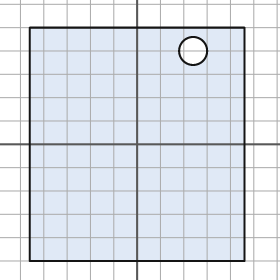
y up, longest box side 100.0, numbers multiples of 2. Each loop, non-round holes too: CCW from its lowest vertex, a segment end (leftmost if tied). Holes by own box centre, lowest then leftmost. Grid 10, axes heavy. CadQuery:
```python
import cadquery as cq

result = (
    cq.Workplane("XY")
    .moveTo(-46.0, -50.0)
    .lineTo(46.0, -50.0)
    .lineTo(46.0, 50.0)
    .lineTo(-46.0, 50.0)
    .close()
    .moveTo(24.0, 40.0)
    .circle(6.0)
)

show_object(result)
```